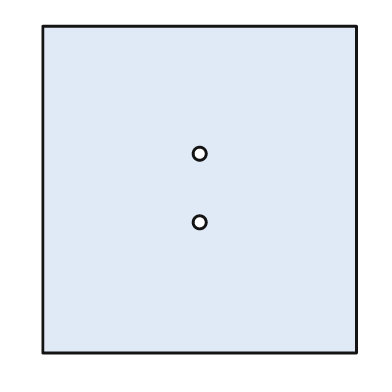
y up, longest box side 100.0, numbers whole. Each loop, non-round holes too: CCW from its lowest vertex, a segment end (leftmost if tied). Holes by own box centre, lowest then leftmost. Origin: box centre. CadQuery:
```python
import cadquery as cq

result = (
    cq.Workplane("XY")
    .moveTo(-48.0, -50.0)
    .lineTo(48.0, -50.0)
    .lineTo(48.0, 50.0)
    .lineTo(-48.0, 50.0)
    .close()
    .moveTo(0.0, -10.0)
    .circle(2.0)
    .moveTo(0.0, 11.0)
    .circle(2.0)
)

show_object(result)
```